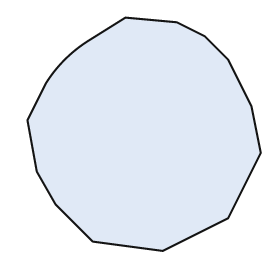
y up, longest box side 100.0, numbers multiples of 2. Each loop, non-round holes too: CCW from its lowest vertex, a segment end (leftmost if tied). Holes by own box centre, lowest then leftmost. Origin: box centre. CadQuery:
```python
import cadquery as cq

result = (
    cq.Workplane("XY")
    .moveTo(8.0, -50.0)
    .lineTo(36.0, -36.0)
    .lineTo(50.0, -8.0)
    .lineTo(46.0, 12.0)
    .lineTo(36.0, 32.0)
    .lineTo(26.0, 42.0)
    .lineTo(14.0, 48.0)
    .lineTo(-8.0, 50.0)
    .lineTo(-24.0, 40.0)
    .threePointArc((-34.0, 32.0), (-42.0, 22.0))
    .lineTo(-50.0, 6.0)
    .lineTo(-46.0, -16.0)
    .lineTo(-38.0, -30.0)
    .lineTo(-22.0, -46.0)
    .close()
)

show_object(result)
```